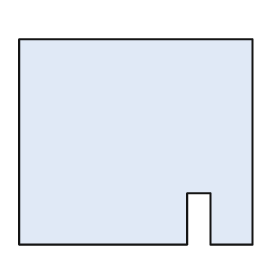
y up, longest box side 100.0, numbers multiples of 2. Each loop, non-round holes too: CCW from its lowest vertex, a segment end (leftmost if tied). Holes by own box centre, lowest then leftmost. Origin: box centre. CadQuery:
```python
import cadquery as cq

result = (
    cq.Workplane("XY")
    .moveTo(-50.0, -44.0)
    .lineTo(22.0, -44.0)
    .lineTo(22.0, -22.0)
    .lineTo(32.0, -22.0)
    .lineTo(32.0, -44.0)
    .lineTo(50.0, -44.0)
    .lineTo(50.0, 44.0)
    .lineTo(-50.0, 44.0)
    .close()
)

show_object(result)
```